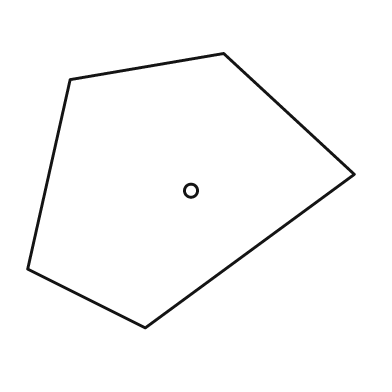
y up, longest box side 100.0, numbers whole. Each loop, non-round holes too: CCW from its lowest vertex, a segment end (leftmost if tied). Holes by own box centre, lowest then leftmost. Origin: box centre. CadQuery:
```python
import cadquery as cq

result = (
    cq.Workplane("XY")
    .moveTo(-14.0, -42.0)
    .lineTo(50.0, 5.0)
    .lineTo(10.0, 42.0)
    .lineTo(-37.0, 34.0)
    .lineTo(-50.0, -24.0)
    .close()
    .moveTo(0.0, 0.0)
    .circle(2.0)
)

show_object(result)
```